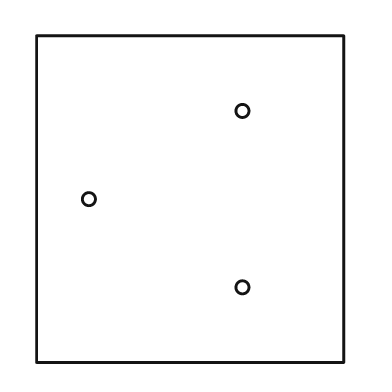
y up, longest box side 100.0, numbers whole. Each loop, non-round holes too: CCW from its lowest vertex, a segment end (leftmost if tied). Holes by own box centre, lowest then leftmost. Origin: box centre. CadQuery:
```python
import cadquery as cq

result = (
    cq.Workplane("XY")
    .moveTo(-47.0, -50.0)
    .lineTo(47.0, -50.0)
    .lineTo(47.0, 50.0)
    .lineTo(-47.0, 50.0)
    .close()
    .moveTo(16.0, -27.0)
    .circle(2.0)
    .moveTo(-31.0, 0.0)
    .circle(2.0)
    .moveTo(16.0, 27.0)
    .circle(2.0)
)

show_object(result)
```